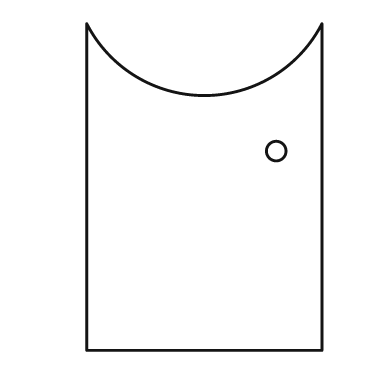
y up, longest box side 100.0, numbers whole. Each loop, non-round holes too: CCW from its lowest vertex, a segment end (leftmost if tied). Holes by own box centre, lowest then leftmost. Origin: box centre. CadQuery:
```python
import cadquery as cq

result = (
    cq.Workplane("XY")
    .moveTo(-36.0, -50.0)
    .lineTo(36.0, -50.0)
    .lineTo(36.0, 50.0)
    .threePointArc((0.0, 28.0), (-36.0, 50.0))
    .close()
    .moveTo(22.0, 11.0)
    .circle(3.0)
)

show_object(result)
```